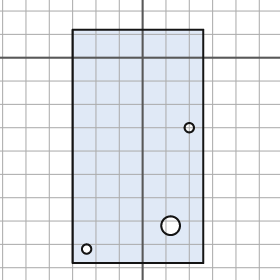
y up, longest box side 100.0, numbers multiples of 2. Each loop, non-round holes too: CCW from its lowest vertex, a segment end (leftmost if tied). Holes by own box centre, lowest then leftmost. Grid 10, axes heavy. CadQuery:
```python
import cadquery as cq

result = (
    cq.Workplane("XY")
    .moveTo(-30.0, -88.0)
    .lineTo(26.0, -88.0)
    .lineTo(26.0, 12.0)
    .lineTo(-30.0, 12.0)
    .close()
    .moveTo(-24.0, -82.0)
    .circle(2.0)
    .moveTo(12.0, -72.0)
    .circle(4.0)
    .moveTo(20.0, -30.0)
    .circle(2.0)
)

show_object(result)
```